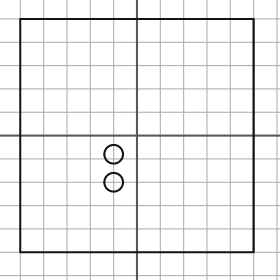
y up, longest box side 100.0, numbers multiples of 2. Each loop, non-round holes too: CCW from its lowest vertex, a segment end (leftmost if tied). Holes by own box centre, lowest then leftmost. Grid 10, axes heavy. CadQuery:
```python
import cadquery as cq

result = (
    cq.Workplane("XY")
    .moveTo(-50.0, -50.0)
    .lineTo(50.0, -50.0)
    .lineTo(50.0, 50.0)
    .lineTo(-50.0, 50.0)
    .close()
    .moveTo(-10.0, -20.0)
    .circle(4.0)
    .moveTo(-10.0, -8.0)
    .circle(4.0)
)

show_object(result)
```